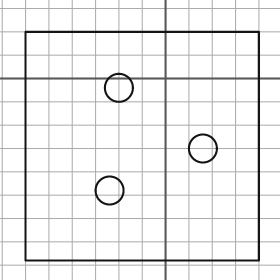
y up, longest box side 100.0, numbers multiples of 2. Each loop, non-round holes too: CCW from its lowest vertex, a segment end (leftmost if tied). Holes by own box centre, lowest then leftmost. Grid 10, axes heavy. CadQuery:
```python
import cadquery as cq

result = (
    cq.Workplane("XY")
    .moveTo(-60.0, -78.0)
    .lineTo(40.0, -78.0)
    .lineTo(40.0, 20.0)
    .lineTo(-60.0, 20.0)
    .close()
    .moveTo(-24.0, -48.0)
    .circle(6.0)
    .moveTo(16.0, -30.0)
    .circle(6.0)
    .moveTo(-20.0, -4.0)
    .circle(6.0)
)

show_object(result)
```